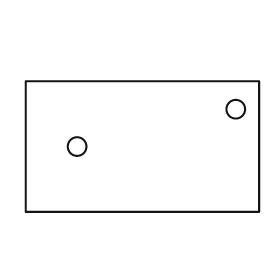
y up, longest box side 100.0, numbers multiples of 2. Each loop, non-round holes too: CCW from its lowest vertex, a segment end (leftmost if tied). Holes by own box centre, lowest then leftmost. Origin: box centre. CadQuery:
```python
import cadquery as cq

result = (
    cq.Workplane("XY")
    .moveTo(-50.0, -28.0)
    .lineTo(50.0, -28.0)
    .lineTo(50.0, 28.0)
    .lineTo(-50.0, 28.0)
    .close()
    .moveTo(-28.0, 0.0)
    .circle(4.0)
    .moveTo(40.0, 16.0)
    .circle(4.0)
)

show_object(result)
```